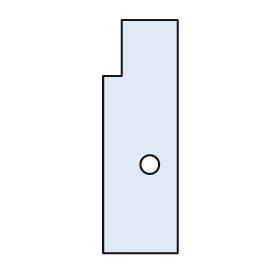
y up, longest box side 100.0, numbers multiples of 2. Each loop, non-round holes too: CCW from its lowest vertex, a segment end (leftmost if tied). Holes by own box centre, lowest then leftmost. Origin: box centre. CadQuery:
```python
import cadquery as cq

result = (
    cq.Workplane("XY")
    .moveTo(-16.0, -50.0)
    .lineTo(16.0, -50.0)
    .lineTo(16.0, 50.0)
    .lineTo(-8.0, 50.0)
    .lineTo(-8.0, 26.0)
    .lineTo(-16.0, 26.0)
    .close()
    .moveTo(4.0, -12.0)
    .circle(4.0)
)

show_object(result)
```